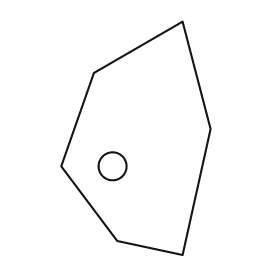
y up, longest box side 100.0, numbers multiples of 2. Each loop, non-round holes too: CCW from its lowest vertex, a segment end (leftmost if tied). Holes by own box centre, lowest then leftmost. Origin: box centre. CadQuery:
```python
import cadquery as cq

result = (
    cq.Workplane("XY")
    .moveTo(20.0, -50.0)
    .lineTo(32.0, 4.0)
    .lineTo(20.0, 50.0)
    .lineTo(-18.0, 28.0)
    .lineTo(-32.0, -12.0)
    .lineTo(-8.0, -44.0)
    .close()
    .moveTo(-10.0, -12.0)
    .circle(6.0)
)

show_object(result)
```